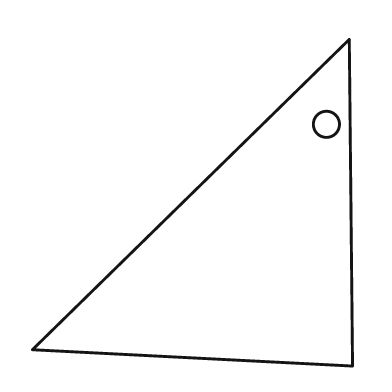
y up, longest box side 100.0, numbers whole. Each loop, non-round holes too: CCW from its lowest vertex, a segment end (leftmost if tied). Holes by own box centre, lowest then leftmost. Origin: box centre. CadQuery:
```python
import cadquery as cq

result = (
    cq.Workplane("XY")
    .moveTo(49.0, -50.0)
    .lineTo(48.0, 50.0)
    .lineTo(-49.0, -45.0)
    .close()
    .moveTo(41.0, 24.0)
    .circle(4.0)
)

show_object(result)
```